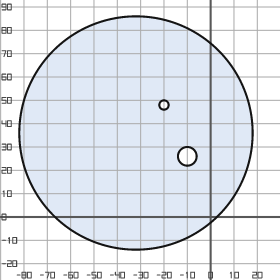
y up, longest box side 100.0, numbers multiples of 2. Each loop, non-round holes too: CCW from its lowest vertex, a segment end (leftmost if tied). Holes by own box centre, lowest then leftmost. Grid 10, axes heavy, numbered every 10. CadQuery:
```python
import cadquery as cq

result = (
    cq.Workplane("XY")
    .moveTo(-32.0, 36.0)
    .circle(50.0)
    .moveTo(-10.0, 26.0)
    .circle(4.0)
    .moveTo(-20.0, 48.0)
    .circle(2.0)
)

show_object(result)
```